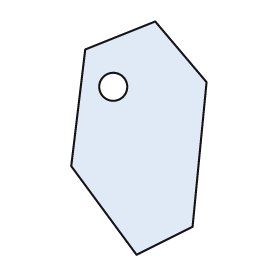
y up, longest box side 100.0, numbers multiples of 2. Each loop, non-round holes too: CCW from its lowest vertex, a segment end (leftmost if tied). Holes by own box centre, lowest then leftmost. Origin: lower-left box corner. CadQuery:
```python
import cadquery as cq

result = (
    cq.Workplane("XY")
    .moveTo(28.0, 0.0)
    .lineTo(52.0, 12.0)
    .lineTo(58.0, 74.0)
    .lineTo(36.0, 100.0)
    .lineTo(6.0, 88.0)
    .lineTo(0.0, 38.0)
    .close()
    .moveTo(18.0, 72.0)
    .circle(6.0)
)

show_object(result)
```